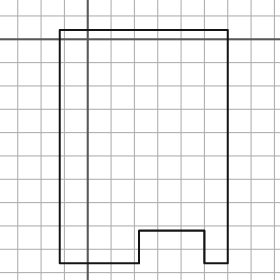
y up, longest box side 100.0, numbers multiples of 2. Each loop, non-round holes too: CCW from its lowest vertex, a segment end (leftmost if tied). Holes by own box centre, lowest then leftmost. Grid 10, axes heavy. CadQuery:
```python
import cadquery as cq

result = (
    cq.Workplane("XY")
    .moveTo(-12.0, -96.0)
    .lineTo(22.0, -96.0)
    .lineTo(22.0, -82.0)
    .lineTo(50.0, -82.0)
    .lineTo(50.0, -96.0)
    .lineTo(60.0, -96.0)
    .lineTo(60.0, 4.0)
    .lineTo(-12.0, 4.0)
    .close()
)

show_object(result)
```